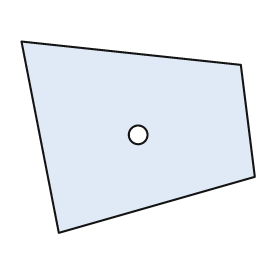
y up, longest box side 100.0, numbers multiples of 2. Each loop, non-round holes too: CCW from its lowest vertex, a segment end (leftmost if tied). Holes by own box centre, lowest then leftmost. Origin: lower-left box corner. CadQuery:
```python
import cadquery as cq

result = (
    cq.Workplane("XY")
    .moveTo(16.0, 0.0)
    .lineTo(100.0, 24.0)
    .lineTo(94.0, 72.0)
    .lineTo(0.0, 82.0)
    .close()
    .moveTo(50.0, 42.0)
    .circle(4.0)
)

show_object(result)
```